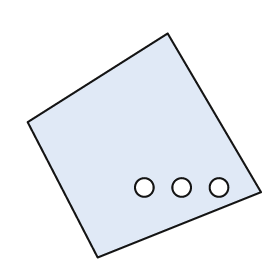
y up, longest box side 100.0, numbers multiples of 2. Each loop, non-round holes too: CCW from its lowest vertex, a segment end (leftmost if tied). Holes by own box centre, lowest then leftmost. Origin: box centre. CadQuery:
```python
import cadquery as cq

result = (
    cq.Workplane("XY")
    .moveTo(-20.0, -48.0)
    .lineTo(50.0, -20.0)
    .lineTo(10.0, 48.0)
    .lineTo(-50.0, 10.0)
    .close()
    .moveTo(0.0, -18.0)
    .circle(4.0)
    .moveTo(16.0, -18.0)
    .circle(4.0)
    .moveTo(32.0, -18.0)
    .circle(4.0)
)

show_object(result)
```